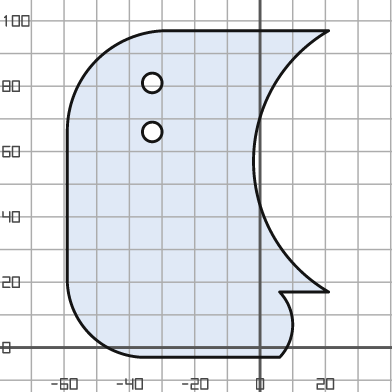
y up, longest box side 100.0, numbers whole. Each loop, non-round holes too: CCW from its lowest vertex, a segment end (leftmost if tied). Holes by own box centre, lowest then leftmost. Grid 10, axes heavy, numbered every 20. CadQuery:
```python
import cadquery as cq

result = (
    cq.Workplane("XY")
    .moveTo(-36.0, -3.0)
    .lineTo(6.0, -3.0)
    .threePointArc((10.0, 7.0), (6.0, 17.0))
    .lineTo(21.0, 17.0)
    .threePointArc((-2.0, 57.0), (21.0, 97.0))
    .lineTo(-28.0, 97.0)
    .threePointArc((-50.0, 88.0), (-59.0, 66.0))
    .lineTo(-59.0, 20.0)
    .threePointArc((-52.0, 4.0), (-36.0, -3.0))
    .close()
    .moveTo(-33.0, 66.0)
    .circle(3.0)
    .moveTo(-33.0, 81.0)
    .circle(3.0)
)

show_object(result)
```